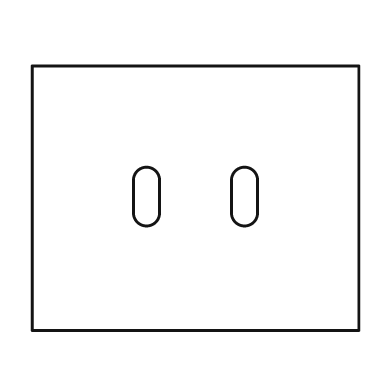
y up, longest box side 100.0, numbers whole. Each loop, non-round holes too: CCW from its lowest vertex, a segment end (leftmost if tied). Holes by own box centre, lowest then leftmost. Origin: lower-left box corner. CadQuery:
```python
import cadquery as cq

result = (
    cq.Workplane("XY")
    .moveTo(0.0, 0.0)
    .lineTo(100.0, 0.0)
    .lineTo(100.0, 81.0)
    .lineTo(0.0, 81.0)
    .close()
    .moveTo(31.0, 36.0)
    .threePointArc((35.0, 32.0), (39.0, 36.0))
    .lineTo(39.0, 46.0)
    .threePointArc((35.0, 50.0), (31.0, 46.0))
    .close()
    .moveTo(61.0, 36.0)
    .threePointArc((65.0, 32.0), (69.0, 36.0))
    .lineTo(69.0, 46.0)
    .threePointArc((65.0, 50.0), (61.0, 46.0))
    .close()
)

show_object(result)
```